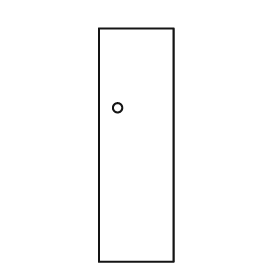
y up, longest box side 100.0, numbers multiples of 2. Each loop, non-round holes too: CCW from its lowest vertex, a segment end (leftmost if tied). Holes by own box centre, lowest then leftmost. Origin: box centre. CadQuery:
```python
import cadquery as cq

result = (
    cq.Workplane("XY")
    .moveTo(-16.0, -50.0)
    .lineTo(16.0, -50.0)
    .lineTo(16.0, 50.0)
    .lineTo(-16.0, 50.0)
    .close()
    .moveTo(-8.0, 16.0)
    .circle(2.0)
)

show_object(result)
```